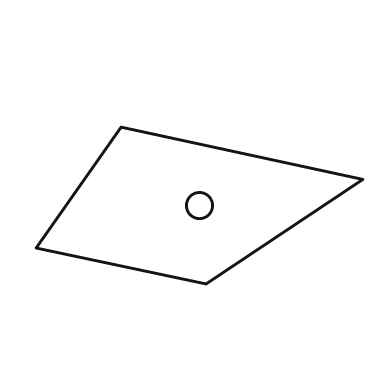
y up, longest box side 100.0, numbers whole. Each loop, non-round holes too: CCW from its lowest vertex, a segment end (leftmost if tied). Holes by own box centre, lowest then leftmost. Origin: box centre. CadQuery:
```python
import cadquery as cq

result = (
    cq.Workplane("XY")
    .moveTo(2.0, -24.0)
    .lineTo(50.0, 8.0)
    .lineTo(-24.0, 24.0)
    .lineTo(-50.0, -13.0)
    .close()
    .moveTo(0.0, 0.0)
    .circle(4.0)
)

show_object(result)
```